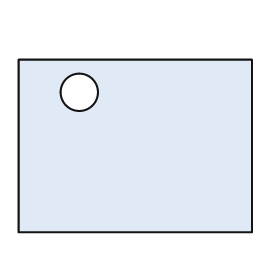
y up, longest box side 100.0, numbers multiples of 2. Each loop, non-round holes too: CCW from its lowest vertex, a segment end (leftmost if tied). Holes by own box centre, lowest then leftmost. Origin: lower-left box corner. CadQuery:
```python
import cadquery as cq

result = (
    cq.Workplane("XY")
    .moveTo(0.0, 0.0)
    .lineTo(100.0, 0.0)
    .lineTo(100.0, 74.0)
    .lineTo(0.0, 74.0)
    .close()
    .moveTo(26.0, 60.0)
    .circle(8.0)
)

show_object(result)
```